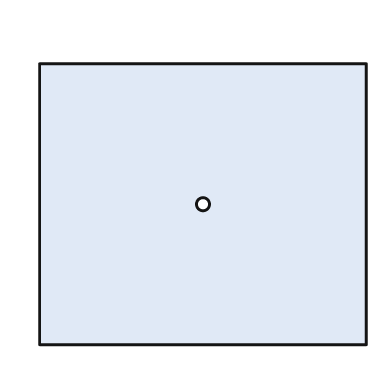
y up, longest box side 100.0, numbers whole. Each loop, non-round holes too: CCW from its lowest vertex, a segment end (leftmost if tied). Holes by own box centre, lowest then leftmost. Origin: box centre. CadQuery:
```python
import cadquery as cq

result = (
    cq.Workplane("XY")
    .moveTo(-50.0, -43.0)
    .lineTo(50.0, -43.0)
    .lineTo(50.0, 43.0)
    .lineTo(-50.0, 43.0)
    .close()
    .moveTo(0.0, 0.0)
    .circle(2.0)
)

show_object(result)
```